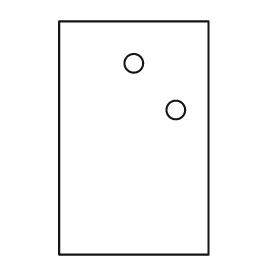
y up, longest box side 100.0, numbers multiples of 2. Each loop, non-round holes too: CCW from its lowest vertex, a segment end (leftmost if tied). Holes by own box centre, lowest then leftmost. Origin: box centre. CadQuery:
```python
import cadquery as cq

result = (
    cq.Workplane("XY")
    .moveTo(-32.0, -50.0)
    .lineTo(32.0, -50.0)
    .lineTo(32.0, 50.0)
    .lineTo(-32.0, 50.0)
    .close()
    .moveTo(18.0, 12.0)
    .circle(4.0)
    .moveTo(0.0, 32.0)
    .circle(4.0)
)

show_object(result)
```